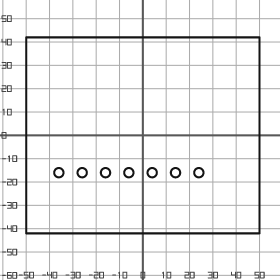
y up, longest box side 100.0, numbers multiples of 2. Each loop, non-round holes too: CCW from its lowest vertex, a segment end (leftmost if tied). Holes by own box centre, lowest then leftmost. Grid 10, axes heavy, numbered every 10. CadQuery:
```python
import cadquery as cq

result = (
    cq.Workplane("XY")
    .moveTo(-50.0, -42.0)
    .lineTo(50.0, -42.0)
    .lineTo(50.0, 42.0)
    .lineTo(-50.0, 42.0)
    .close()
    .moveTo(-36.0, -16.0)
    .circle(2.0)
    .moveTo(-26.0, -16.0)
    .circle(2.0)
    .moveTo(-16.0, -16.0)
    .circle(2.0)
    .moveTo(-6.0, -16.0)
    .circle(2.0)
    .moveTo(4.0, -16.0)
    .circle(2.0)
    .moveTo(14.0, -16.0)
    .circle(2.0)
    .moveTo(24.0, -16.0)
    .circle(2.0)
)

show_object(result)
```